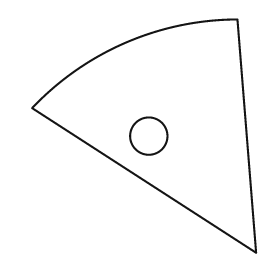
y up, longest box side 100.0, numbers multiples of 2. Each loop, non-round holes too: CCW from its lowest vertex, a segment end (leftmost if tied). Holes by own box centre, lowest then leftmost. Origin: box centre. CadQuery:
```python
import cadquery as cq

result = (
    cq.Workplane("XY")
    .moveTo(48.0, -50.0)
    .lineTo(40.0, 50.0)
    .threePointArc((-8.0, 40.0), (-48.0, 12.0))
    .close()
    .moveTo(2.0, 0.0)
    .circle(8.0)
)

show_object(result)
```